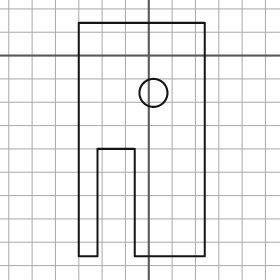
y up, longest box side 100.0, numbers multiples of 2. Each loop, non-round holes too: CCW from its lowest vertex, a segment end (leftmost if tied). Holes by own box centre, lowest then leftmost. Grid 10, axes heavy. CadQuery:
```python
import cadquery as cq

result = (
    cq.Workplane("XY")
    .moveTo(-30.0, -86.0)
    .lineTo(-22.0, -86.0)
    .lineTo(-22.0, -40.0)
    .lineTo(-6.0, -40.0)
    .lineTo(-6.0, -86.0)
    .lineTo(24.0, -86.0)
    .lineTo(24.0, 14.0)
    .lineTo(-30.0, 14.0)
    .close()
    .moveTo(2.0, -16.0)
    .circle(6.0)
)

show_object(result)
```